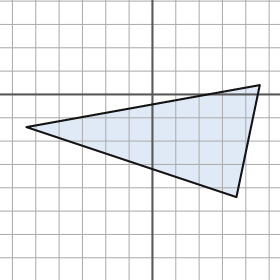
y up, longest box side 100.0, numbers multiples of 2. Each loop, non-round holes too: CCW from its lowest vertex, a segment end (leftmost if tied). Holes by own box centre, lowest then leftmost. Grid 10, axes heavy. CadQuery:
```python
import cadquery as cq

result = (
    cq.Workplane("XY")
    .moveTo(36.0, -44.0)
    .lineTo(46.0, 4.0)
    .lineTo(-54.0, -14.0)
    .close()
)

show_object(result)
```